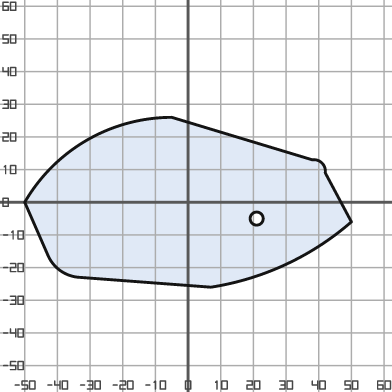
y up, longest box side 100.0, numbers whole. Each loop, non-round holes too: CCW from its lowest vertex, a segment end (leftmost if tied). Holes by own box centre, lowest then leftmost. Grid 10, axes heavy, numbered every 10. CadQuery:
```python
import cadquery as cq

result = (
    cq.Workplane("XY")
    .moveTo(7.0, -26.0)
    .threePointArc((30.0, -19.0), (50.0, -6.0))
    .lineTo(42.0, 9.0)
    .threePointArc((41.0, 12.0), (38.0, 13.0))
    .lineTo(-5.0, 26.0)
    .threePointArc((-31.0, 19.0), (-50.0, 0.0))
    .lineTo(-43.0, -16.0)
    .threePointArc((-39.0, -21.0), (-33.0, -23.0))
    .close()
    .moveTo(21.0, -5.0)
    .circle(2.0)
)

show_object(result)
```